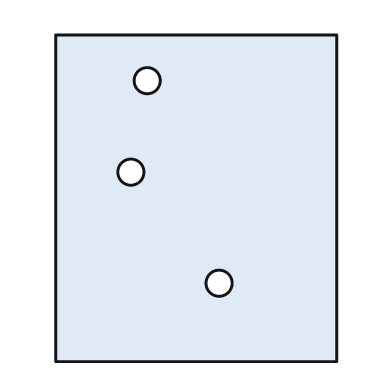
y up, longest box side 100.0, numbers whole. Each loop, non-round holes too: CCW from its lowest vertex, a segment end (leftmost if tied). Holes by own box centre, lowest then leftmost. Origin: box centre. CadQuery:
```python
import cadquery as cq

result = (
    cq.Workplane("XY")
    .moveTo(-43.0, -50.0)
    .lineTo(43.0, -50.0)
    .lineTo(43.0, 50.0)
    .lineTo(-43.0, 50.0)
    .close()
    .moveTo(7.0, -26.0)
    .circle(4.0)
    .moveTo(-20.0, 8.0)
    .circle(4.0)
    .moveTo(-15.0, 36.0)
    .circle(4.0)
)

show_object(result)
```